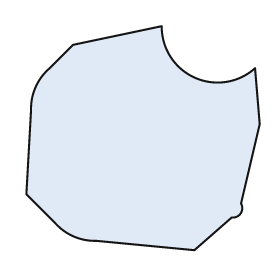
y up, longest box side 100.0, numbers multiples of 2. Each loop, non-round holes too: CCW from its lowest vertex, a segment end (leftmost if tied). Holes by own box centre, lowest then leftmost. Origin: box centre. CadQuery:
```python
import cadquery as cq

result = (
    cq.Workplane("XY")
    .moveTo(22.0, -48.0)
    .lineTo(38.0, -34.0)
    .threePointArc((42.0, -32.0), (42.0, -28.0))
    .lineTo(50.0, 6.0)
    .lineTo(48.0, 30.0)
    .threePointArc((22.0, 26.0), (8.0, 48.0))
    .lineTo(-30.0, 40.0)
    .lineTo(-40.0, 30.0)
    .threePointArc((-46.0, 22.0), (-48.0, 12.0))
    .lineTo(-50.0, -24.0)
    .lineTo(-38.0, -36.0)
    .threePointArc((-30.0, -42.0), (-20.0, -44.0))
    .close()
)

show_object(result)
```